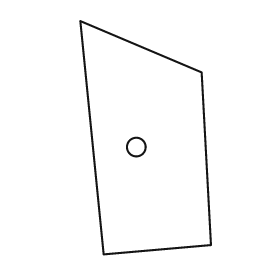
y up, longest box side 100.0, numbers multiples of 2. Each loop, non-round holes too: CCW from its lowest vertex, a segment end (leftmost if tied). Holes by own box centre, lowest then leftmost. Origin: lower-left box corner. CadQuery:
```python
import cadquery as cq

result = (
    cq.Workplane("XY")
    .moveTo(10.0, 0.0)
    .lineTo(56.0, 4.0)
    .lineTo(52.0, 78.0)
    .lineTo(0.0, 100.0)
    .close()
    .moveTo(24.0, 46.0)
    .circle(4.0)
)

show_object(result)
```